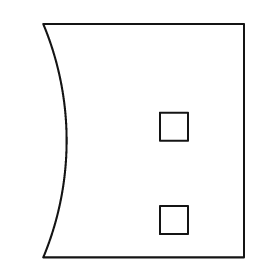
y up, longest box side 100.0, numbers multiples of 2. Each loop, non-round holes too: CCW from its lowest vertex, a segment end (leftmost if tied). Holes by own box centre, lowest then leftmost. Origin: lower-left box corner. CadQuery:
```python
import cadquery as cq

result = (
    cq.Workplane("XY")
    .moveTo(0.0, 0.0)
    .lineTo(86.0, 0.0)
    .lineTo(86.0, 100.0)
    .lineTo(0.0, 100.0)
    .threePointArc((10.0, 50.0), (0.0, 0.0))
    .close()
    .moveTo(50.0, 10.0)
    .lineTo(62.0, 10.0)
    .lineTo(62.0, 22.0)
    .lineTo(50.0, 22.0)
    .close()
    .moveTo(50.0, 50.0)
    .lineTo(62.0, 50.0)
    .lineTo(62.0, 62.0)
    .lineTo(50.0, 62.0)
    .close()
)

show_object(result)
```